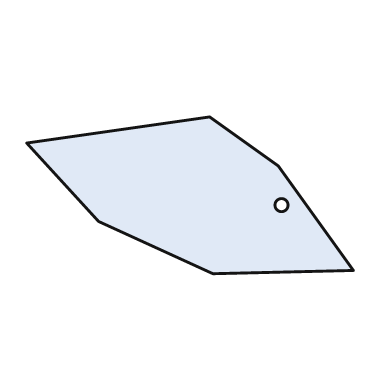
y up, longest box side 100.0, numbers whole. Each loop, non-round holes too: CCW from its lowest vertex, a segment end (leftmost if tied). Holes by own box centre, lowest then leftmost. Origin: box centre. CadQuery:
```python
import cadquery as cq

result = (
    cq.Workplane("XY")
    .moveTo(7.0, -24.0)
    .lineTo(50.0, -23.0)
    .lineTo(27.0, 9.0)
    .lineTo(6.0, 24.0)
    .lineTo(-50.0, 16.0)
    .lineTo(-28.0, -8.0)
    .close()
    .moveTo(28.0, -3.0)
    .circle(2.0)
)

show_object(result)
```